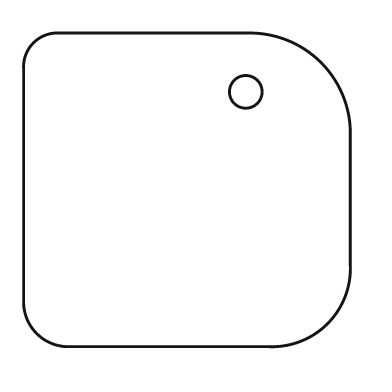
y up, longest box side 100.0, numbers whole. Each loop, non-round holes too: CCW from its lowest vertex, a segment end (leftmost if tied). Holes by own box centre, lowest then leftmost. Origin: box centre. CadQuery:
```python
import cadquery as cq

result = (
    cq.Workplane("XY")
    .moveTo(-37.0, -48.0)
    .lineTo(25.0, -48.0)
    .threePointArc((43.0, -41.0), (50.0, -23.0))
    .lineTo(50.0, 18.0)
    .threePointArc((41.0, 39.0), (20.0, 48.0))
    .lineTo(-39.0, 48.0)
    .threePointArc((-47.0, 45.0), (-50.0, 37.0))
    .lineTo(-50.0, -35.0)
    .threePointArc((-46.0, -44.0), (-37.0, -48.0))
    .close()
    .moveTo(18.0, 30.0)
    .circle(5.0)
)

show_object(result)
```